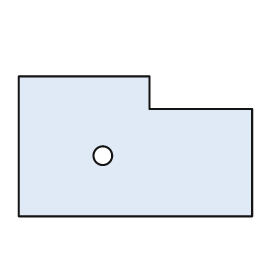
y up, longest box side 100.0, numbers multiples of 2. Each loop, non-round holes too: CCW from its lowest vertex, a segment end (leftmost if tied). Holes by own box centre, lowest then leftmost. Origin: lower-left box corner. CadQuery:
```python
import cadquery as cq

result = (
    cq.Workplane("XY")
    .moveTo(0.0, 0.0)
    .lineTo(100.0, 0.0)
    .lineTo(100.0, 46.0)
    .lineTo(56.0, 46.0)
    .lineTo(56.0, 60.0)
    .lineTo(0.0, 60.0)
    .close()
    .moveTo(36.0, 26.0)
    .circle(4.0)
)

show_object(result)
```